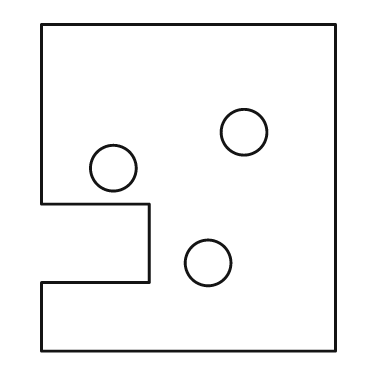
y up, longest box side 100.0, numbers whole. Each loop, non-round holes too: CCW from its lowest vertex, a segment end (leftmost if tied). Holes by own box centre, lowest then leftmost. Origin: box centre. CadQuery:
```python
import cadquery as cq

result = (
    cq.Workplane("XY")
    .moveTo(-45.0, -50.0)
    .lineTo(45.0, -50.0)
    .lineTo(45.0, 50.0)
    .lineTo(-45.0, 50.0)
    .lineTo(-45.0, -5.0)
    .lineTo(-12.0, -5.0)
    .lineTo(-12.0, -29.0)
    .lineTo(-45.0, -29.0)
    .close()
    .moveTo(6.0, -23.0)
    .circle(7.0)
    .moveTo(-23.0, 6.0)
    .circle(7.0)
    .moveTo(17.0, 17.0)
    .circle(7.0)
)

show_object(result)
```